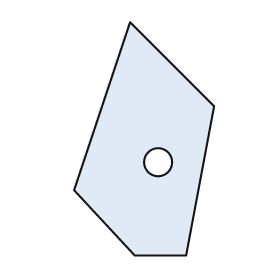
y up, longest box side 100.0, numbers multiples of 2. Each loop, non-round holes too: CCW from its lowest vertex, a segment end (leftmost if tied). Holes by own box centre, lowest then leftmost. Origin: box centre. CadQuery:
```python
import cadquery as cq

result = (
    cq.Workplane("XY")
    .moveTo(-4.0, -50.0)
    .lineTo(18.0, -50.0)
    .lineTo(30.0, 14.0)
    .lineTo(-6.0, 50.0)
    .lineTo(-30.0, -22.0)
    .close()
    .moveTo(6.0, -10.0)
    .circle(6.0)
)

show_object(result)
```